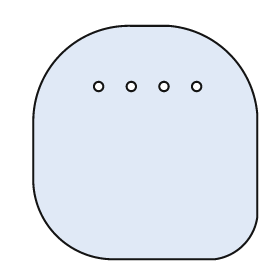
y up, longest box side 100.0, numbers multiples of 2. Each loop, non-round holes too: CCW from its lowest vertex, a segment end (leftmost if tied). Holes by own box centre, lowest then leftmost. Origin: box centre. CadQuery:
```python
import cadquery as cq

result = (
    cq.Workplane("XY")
    .moveTo(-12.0, -50.0)
    .lineTo(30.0, -50.0)
    .threePointArc((42.0, -44.0), (48.0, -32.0))
    .lineTo(48.0, 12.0)
    .threePointArc((36.0, 38.0), (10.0, 50.0))
    .lineTo(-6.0, 50.0)
    .threePointArc((-36.0, 38.0), (-48.0, 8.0))
    .lineTo(-48.0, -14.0)
    .threePointArc((-38.0, -40.0), (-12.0, -50.0))
    .close()
    .moveTo(-20.0, 24.0)
    .circle(2.0)
    .moveTo(-6.0, 24.0)
    .circle(2.0)
    .moveTo(8.0, 24.0)
    .circle(2.0)
    .moveTo(22.0, 24.0)
    .circle(2.0)
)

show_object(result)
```